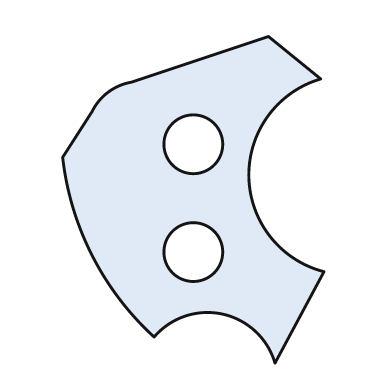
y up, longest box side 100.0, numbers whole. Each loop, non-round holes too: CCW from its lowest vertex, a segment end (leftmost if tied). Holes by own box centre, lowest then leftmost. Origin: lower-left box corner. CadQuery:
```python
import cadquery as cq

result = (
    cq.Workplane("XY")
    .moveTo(65.0, 0.0)
    .lineTo(80.0, 28.0)
    .threePointArc((57.0, 57.0), (79.0, 87.0))
    .lineTo(63.0, 100.0)
    .lineTo(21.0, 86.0)
    .threePointArc((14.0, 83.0), (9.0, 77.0))
    .lineTo(0.0, 63.0)
    .threePointArc((9.0, 33.0), (28.0, 8.0))
    .threePointArc((49.0, 15.0), (65.0, 0.0))
    .close()
    .moveTo(40.0, 34.0)
    .circle(9.0)
    .moveTo(40.0, 67.0)
    .circle(9.0)
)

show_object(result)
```